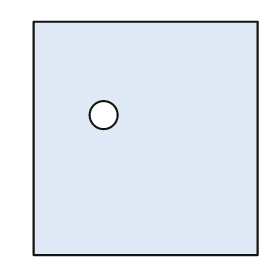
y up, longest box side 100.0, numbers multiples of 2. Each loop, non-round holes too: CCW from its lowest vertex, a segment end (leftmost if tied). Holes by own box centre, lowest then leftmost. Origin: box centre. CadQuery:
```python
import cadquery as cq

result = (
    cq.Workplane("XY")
    .moveTo(-48.0, -50.0)
    .lineTo(48.0, -50.0)
    .lineTo(48.0, 50.0)
    .lineTo(-48.0, 50.0)
    .close()
    .moveTo(-18.0, 10.0)
    .circle(6.0)
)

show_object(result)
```